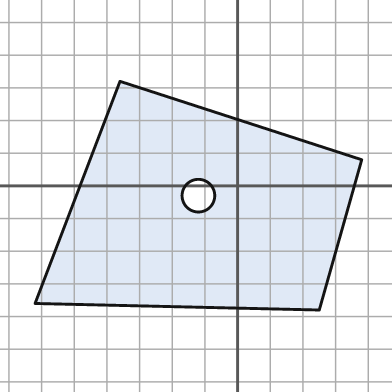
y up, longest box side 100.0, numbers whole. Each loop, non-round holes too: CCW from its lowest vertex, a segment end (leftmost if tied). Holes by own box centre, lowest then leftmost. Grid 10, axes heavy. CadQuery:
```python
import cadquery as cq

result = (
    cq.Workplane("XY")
    .moveTo(25.0, -38.0)
    .lineTo(38.0, 8.0)
    .lineTo(-36.0, 32.0)
    .lineTo(-62.0, -36.0)
    .close()
    .moveTo(-12.0, -3.0)
    .circle(5.0)
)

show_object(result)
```